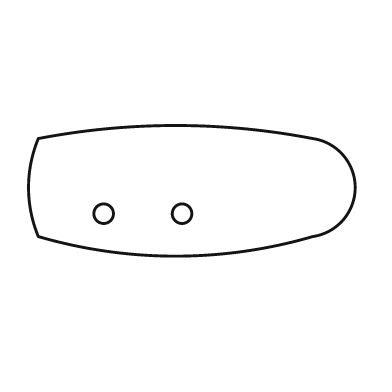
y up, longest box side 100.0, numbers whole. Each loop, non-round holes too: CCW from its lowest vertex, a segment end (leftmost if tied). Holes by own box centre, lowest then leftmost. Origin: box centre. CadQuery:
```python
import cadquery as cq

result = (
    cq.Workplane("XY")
    .moveTo(-47.0, -14.0)
    .threePointArc((-5.0, -20.0), (37.0, -14.0))
    .threePointArc((50.0, 1.0), (37.0, 16.0))
    .threePointArc((-5.0, 20.0), (-47.0, 16.0))
    .threePointArc((-50.0, 1.0), (-47.0, -14.0))
    .close()
    .moveTo(-27.0, -7.0)
    .circle(3.0)
    .moveTo(-3.0, -7.0)
    .circle(3.0)
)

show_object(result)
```